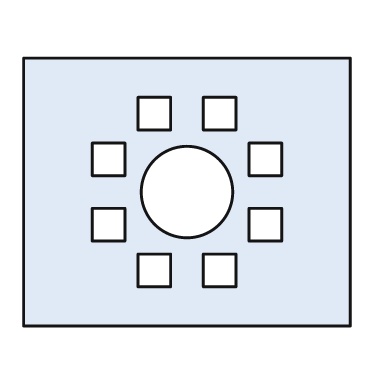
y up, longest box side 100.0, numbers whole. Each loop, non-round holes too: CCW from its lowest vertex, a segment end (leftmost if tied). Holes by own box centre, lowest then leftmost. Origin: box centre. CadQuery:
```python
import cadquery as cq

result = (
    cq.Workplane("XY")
    .moveTo(-50.0, -41.0)
    .lineTo(50.0, -41.0)
    .lineTo(50.0, 41.0)
    .lineTo(-50.0, 41.0)
    .close()
    .moveTo(-15.0, -29.0)
    .lineTo(-5.0, -29.0)
    .lineTo(-5.0, -19.0)
    .lineTo(-15.0, -19.0)
    .close()
    .moveTo(5.0, -29.0)
    .lineTo(15.0, -29.0)
    .lineTo(15.0, -19.0)
    .lineTo(5.0, -19.0)
    .close()
    .moveTo(-29.0, -15.0)
    .lineTo(-19.0, -15.0)
    .lineTo(-19.0, -5.0)
    .lineTo(-29.0, -5.0)
    .close()
    .moveTo(19.0, -15.0)
    .lineTo(29.0, -15.0)
    .lineTo(29.0, -5.0)
    .lineTo(19.0, -5.0)
    .close()
    .moveTo(0.0, 0.0)
    .circle(14.0)
    .moveTo(-29.0, 5.0)
    .lineTo(-19.0, 5.0)
    .lineTo(-19.0, 15.0)
    .lineTo(-29.0, 15.0)
    .close()
    .moveTo(19.0, 5.0)
    .lineTo(29.0, 5.0)
    .lineTo(29.0, 15.0)
    .lineTo(19.0, 15.0)
    .close()
    .moveTo(-15.0, 19.0)
    .lineTo(-5.0, 19.0)
    .lineTo(-5.0, 29.0)
    .lineTo(-15.0, 29.0)
    .close()
    .moveTo(5.0, 19.0)
    .lineTo(15.0, 19.0)
    .lineTo(15.0, 29.0)
    .lineTo(5.0, 29.0)
    .close()
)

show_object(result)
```